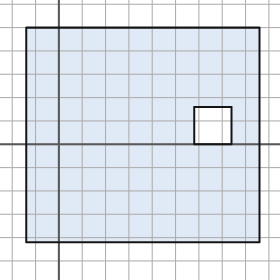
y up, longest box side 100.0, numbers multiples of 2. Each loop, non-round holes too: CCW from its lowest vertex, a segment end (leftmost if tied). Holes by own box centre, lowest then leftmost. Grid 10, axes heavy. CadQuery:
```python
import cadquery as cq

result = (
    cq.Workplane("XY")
    .moveTo(-14.0, -42.0)
    .lineTo(86.0, -42.0)
    .lineTo(86.0, 50.0)
    .lineTo(-14.0, 50.0)
    .close()
    .moveTo(58.0, 0.0)
    .lineTo(74.0, 0.0)
    .lineTo(74.0, 16.0)
    .lineTo(58.0, 16.0)
    .close()
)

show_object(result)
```